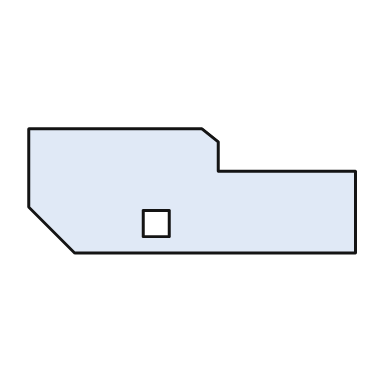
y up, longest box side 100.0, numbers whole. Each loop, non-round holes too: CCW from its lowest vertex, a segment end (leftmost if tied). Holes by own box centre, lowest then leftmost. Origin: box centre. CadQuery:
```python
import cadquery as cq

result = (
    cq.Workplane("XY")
    .moveTo(-36.0, -19.0)
    .lineTo(50.0, -19.0)
    .lineTo(50.0, 6.0)
    .lineTo(8.0, 6.0)
    .lineTo(8.0, 15.0)
    .lineTo(3.0, 19.0)
    .lineTo(-50.0, 19.0)
    .lineTo(-50.0, -5.0)
    .close()
    .moveTo(-15.0, -14.0)
    .lineTo(-7.0, -14.0)
    .lineTo(-7.0, -6.0)
    .lineTo(-15.0, -6.0)
    .close()
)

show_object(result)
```